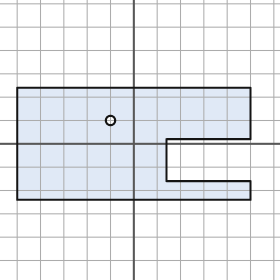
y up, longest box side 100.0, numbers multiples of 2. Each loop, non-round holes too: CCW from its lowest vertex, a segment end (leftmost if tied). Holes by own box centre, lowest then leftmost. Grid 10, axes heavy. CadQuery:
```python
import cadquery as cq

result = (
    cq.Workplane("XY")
    .moveTo(-50.0, -24.0)
    .lineTo(50.0, -24.0)
    .lineTo(50.0, -16.0)
    .lineTo(14.0, -16.0)
    .lineTo(14.0, 2.0)
    .lineTo(50.0, 2.0)
    .lineTo(50.0, 24.0)
    .lineTo(-50.0, 24.0)
    .close()
    .moveTo(-10.0, 10.0)
    .circle(2.0)
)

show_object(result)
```